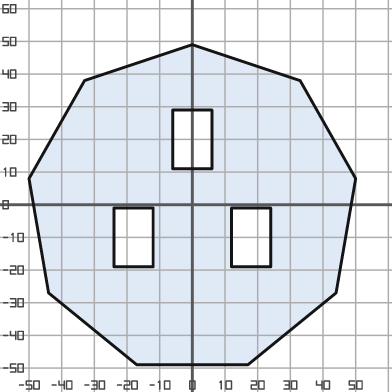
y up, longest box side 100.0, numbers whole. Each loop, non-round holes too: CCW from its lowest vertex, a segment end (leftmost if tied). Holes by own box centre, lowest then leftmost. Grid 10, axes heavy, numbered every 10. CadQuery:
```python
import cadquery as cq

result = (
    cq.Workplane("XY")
    .moveTo(-17.0, -49.0)
    .lineTo(17.0, -49.0)
    .lineTo(44.0, -27.0)
    .lineTo(50.0, 8.0)
    .lineTo(33.0, 38.0)
    .lineTo(0.0, 49.0)
    .lineTo(-33.0, 38.0)
    .lineTo(-50.0, 8.0)
    .lineTo(-44.0, -27.0)
    .close()
    .moveTo(-24.0, -19.0)
    .lineTo(-12.0, -19.0)
    .lineTo(-12.0, -1.0)
    .lineTo(-24.0, -1.0)
    .close()
    .moveTo(12.0, -19.0)
    .lineTo(24.0, -19.0)
    .lineTo(24.0, -1.0)
    .lineTo(12.0, -1.0)
    .close()
    .moveTo(-6.0, 11.0)
    .lineTo(6.0, 11.0)
    .lineTo(6.0, 29.0)
    .lineTo(-6.0, 29.0)
    .close()
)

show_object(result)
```